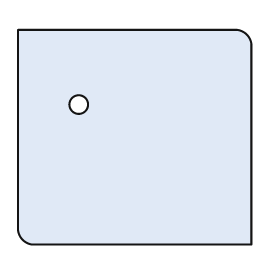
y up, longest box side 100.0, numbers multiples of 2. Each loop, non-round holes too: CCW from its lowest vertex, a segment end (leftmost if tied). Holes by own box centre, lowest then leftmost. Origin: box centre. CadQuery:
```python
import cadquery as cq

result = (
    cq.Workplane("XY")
    .moveTo(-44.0, -46.0)
    .lineTo(50.0, -46.0)
    .lineTo(50.0, 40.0)
    .threePointArc((48.0, 44.0), (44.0, 46.0))
    .lineTo(-50.0, 46.0)
    .lineTo(-50.0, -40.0)
    .threePointArc((-48.0, -44.0), (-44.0, -46.0))
    .close()
    .moveTo(-24.0, 14.0)
    .circle(4.0)
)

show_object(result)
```